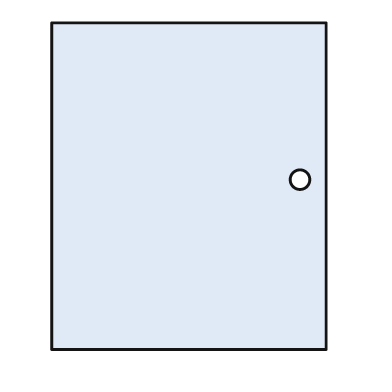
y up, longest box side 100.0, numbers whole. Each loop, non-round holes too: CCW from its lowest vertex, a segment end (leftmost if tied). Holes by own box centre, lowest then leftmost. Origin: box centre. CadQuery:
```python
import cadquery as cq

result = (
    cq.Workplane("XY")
    .moveTo(-42.0, -50.0)
    .lineTo(42.0, -50.0)
    .lineTo(42.0, 50.0)
    .lineTo(-42.0, 50.0)
    .close()
    .moveTo(34.0, 2.0)
    .circle(3.0)
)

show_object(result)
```